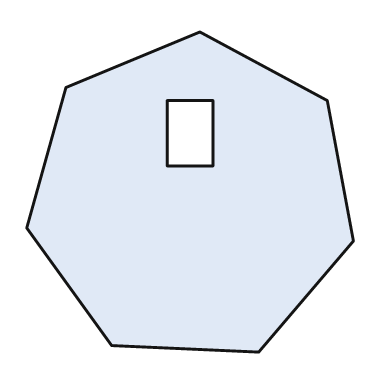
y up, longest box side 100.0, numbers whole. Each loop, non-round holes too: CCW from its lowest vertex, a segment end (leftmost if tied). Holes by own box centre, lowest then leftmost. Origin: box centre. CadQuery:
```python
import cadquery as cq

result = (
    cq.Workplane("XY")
    .moveTo(21.0, -49.0)
    .lineTo(50.0, -15.0)
    .lineTo(42.0, 28.0)
    .lineTo(3.0, 49.0)
    .lineTo(-38.0, 32.0)
    .lineTo(-50.0, -11.0)
    .lineTo(-24.0, -47.0)
    .close()
    .moveTo(-7.0, 8.0)
    .lineTo(7.0, 8.0)
    .lineTo(7.0, 28.0)
    .lineTo(-7.0, 28.0)
    .close()
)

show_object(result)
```